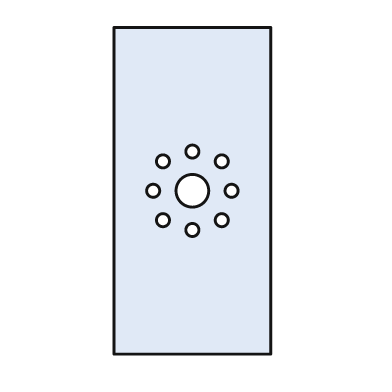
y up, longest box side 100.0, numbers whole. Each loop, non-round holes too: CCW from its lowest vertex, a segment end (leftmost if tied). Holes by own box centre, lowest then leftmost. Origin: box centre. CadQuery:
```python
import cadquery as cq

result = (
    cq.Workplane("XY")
    .moveTo(-24.0, -50.0)
    .lineTo(24.0, -50.0)
    .lineTo(24.0, 50.0)
    .lineTo(-24.0, 50.0)
    .close()
    .moveTo(0.0, -12.0)
    .circle(2.0)
    .moveTo(-9.0, -9.0)
    .circle(2.0)
    .moveTo(9.0, -9.0)
    .circle(2.0)
    .moveTo(-12.0, 0.0)
    .circle(2.0)
    .moveTo(0.0, 0.0)
    .circle(5.0)
    .moveTo(12.0, 0.0)
    .circle(2.0)
    .moveTo(-9.0, 9.0)
    .circle(2.0)
    .moveTo(9.0, 9.0)
    .circle(2.0)
    .moveTo(0.0, 12.0)
    .circle(2.0)
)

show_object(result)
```